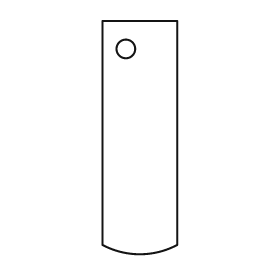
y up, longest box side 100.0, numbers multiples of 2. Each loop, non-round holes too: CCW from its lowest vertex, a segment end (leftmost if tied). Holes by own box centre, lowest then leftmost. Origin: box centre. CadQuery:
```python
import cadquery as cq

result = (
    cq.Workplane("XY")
    .moveTo(-16.0, -46.0)
    .threePointArc((0.0, -50.0), (16.0, -46.0))
    .lineTo(16.0, 50.0)
    .lineTo(-16.0, 50.0)
    .close()
    .moveTo(-6.0, 38.0)
    .circle(4.0)
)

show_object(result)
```